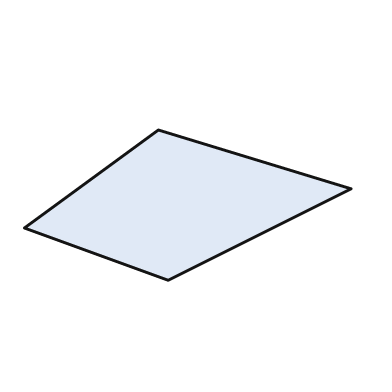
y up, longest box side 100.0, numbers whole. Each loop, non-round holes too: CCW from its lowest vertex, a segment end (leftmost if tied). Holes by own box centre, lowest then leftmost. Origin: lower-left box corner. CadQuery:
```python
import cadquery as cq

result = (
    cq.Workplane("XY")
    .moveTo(44.0, 0.0)
    .lineTo(100.0, 28.0)
    .lineTo(41.0, 46.0)
    .lineTo(0.0, 16.0)
    .close()
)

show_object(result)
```